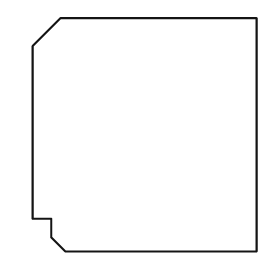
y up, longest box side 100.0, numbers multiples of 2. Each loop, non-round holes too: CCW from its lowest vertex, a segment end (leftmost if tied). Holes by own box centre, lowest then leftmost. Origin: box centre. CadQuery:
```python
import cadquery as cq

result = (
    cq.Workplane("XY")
    .moveTo(-34.0, -50.0)
    .lineTo(48.0, -50.0)
    .lineTo(48.0, 50.0)
    .lineTo(-36.0, 50.0)
    .lineTo(-48.0, 38.0)
    .lineTo(-48.0, -36.0)
    .lineTo(-40.0, -36.0)
    .lineTo(-40.0, -44.0)
    .close()
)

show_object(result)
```